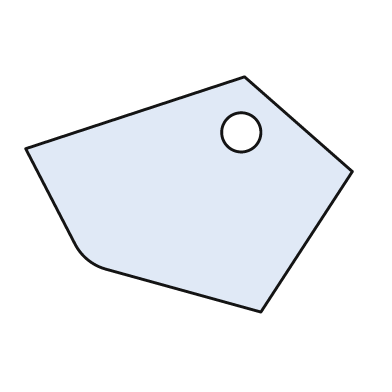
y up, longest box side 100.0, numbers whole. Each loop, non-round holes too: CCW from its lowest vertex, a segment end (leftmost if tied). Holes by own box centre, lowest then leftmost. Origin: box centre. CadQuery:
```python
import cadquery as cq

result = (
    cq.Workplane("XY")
    .moveTo(22.0, -36.0)
    .lineTo(50.0, 7.0)
    .lineTo(17.0, 36.0)
    .lineTo(-50.0, 14.0)
    .lineTo(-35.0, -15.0)
    .threePointArc((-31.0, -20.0), (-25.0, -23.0))
    .close()
    .moveTo(16.0, 19.0)
    .circle(6.0)
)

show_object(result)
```